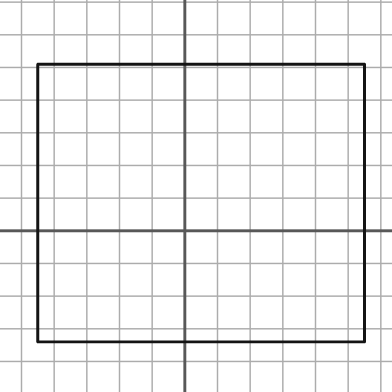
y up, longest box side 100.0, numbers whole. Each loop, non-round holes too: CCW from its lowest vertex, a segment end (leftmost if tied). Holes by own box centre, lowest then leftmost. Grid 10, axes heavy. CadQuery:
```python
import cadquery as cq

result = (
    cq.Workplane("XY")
    .moveTo(-45.0, -34.0)
    .lineTo(55.0, -34.0)
    .lineTo(55.0, 51.0)
    .lineTo(-45.0, 51.0)
    .close()
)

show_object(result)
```